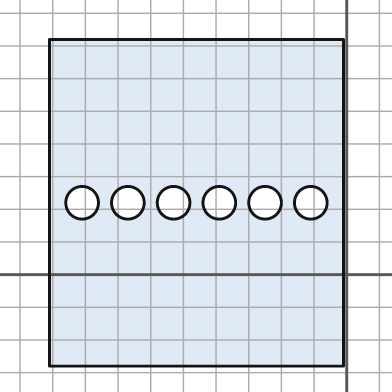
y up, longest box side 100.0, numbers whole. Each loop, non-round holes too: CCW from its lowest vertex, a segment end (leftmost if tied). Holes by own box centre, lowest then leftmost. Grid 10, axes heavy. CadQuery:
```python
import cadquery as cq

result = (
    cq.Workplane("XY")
    .moveTo(-91.0, -28.0)
    .lineTo(-1.0, -28.0)
    .lineTo(-1.0, 72.0)
    .lineTo(-91.0, 72.0)
    .close()
    .moveTo(-81.0, 22.0)
    .circle(5.0)
    .moveTo(-67.0, 22.0)
    .circle(5.0)
    .moveTo(-53.0, 22.0)
    .circle(5.0)
    .moveTo(-39.0, 22.0)
    .circle(5.0)
    .moveTo(-25.0, 22.0)
    .circle(5.0)
    .moveTo(-11.0, 22.0)
    .circle(5.0)
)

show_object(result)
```